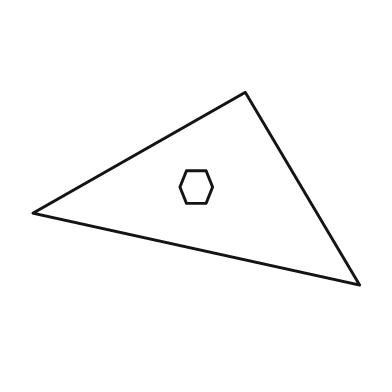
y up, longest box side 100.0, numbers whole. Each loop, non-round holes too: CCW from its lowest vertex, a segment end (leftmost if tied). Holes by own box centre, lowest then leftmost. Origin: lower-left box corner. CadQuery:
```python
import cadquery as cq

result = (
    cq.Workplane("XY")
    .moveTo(100.0, 0.0)
    .lineTo(65.0, 59.0)
    .lineTo(0.0, 22.0)
    .close()
    .moveTo(47.0, 25.0)
    .lineTo(53.0, 25.0)
    .lineTo(55.0, 30.0)
    .lineTo(53.0, 35.0)
    .lineTo(47.0, 35.0)
    .lineTo(45.0, 30.0)
    .close()
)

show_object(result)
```